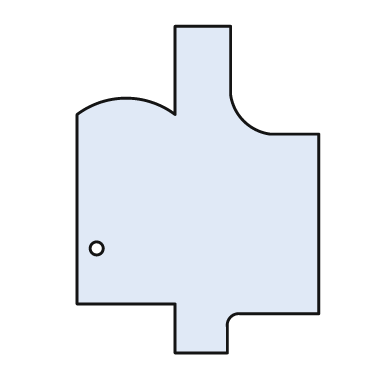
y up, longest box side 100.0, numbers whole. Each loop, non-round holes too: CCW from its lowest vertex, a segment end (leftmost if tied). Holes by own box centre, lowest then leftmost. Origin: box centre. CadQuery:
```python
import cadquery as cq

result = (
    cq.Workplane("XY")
    .moveTo(-7.0, -50.0)
    .lineTo(9.0, -50.0)
    .lineTo(9.0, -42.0)
    .threePointArc((10.0, -39.0), (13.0, -38.0))
    .lineTo(37.0, -38.0)
    .lineTo(37.0, 17.0)
    .lineTo(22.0, 17.0)
    .threePointArc((14.0, 21.0), (10.0, 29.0))
    .lineTo(10.0, 50.0)
    .lineTo(-7.0, 50.0)
    .lineTo(-7.0, 23.0)
    .threePointArc((-22.0, 28.0), (-37.0, 23.0))
    .lineTo(-37.0, -35.0)
    .lineTo(-7.0, -35.0)
    .close()
    .moveTo(-31.0, -18.0)
    .circle(2.0)
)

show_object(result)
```